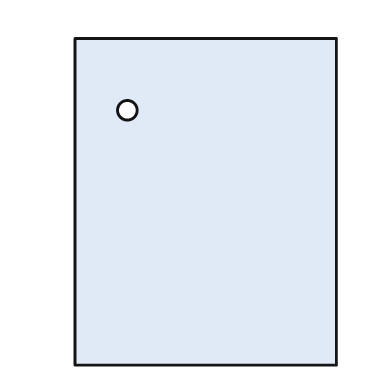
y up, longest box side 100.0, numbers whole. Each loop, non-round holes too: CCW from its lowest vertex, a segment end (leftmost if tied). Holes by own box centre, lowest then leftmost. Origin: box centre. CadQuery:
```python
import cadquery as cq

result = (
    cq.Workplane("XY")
    .moveTo(-40.0, -50.0)
    .lineTo(40.0, -50.0)
    .lineTo(40.0, 50.0)
    .lineTo(-40.0, 50.0)
    .close()
    .moveTo(-24.0, 28.0)
    .circle(3.0)
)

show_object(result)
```